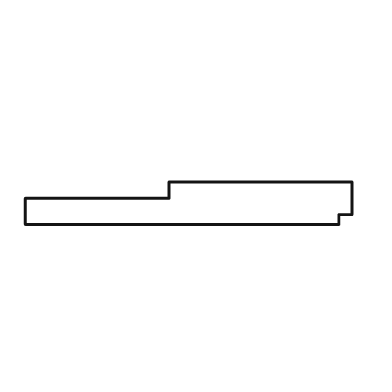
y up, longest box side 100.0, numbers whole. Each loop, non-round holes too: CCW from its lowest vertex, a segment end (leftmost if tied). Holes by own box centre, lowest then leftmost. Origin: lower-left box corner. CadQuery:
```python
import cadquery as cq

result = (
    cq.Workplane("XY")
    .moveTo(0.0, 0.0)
    .lineTo(96.0, 0.0)
    .lineTo(96.0, 3.0)
    .lineTo(100.0, 3.0)
    .lineTo(100.0, 13.0)
    .lineTo(44.0, 13.0)
    .lineTo(44.0, 8.0)
    .lineTo(0.0, 8.0)
    .close()
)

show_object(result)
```